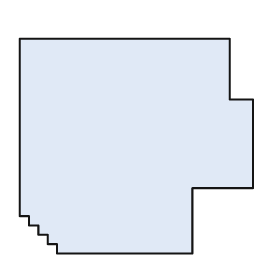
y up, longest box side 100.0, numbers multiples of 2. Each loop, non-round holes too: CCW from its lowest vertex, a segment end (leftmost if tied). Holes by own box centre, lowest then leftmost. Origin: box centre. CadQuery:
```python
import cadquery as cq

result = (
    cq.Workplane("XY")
    .moveTo(-34.0, -46.0)
    .lineTo(24.0, -46.0)
    .lineTo(24.0, -18.0)
    .lineTo(50.0, -18.0)
    .lineTo(50.0, 20.0)
    .lineTo(40.0, 20.0)
    .lineTo(40.0, 46.0)
    .lineTo(-50.0, 46.0)
    .lineTo(-50.0, -30.0)
    .lineTo(-46.0, -30.0)
    .lineTo(-46.0, -34.0)
    .lineTo(-42.0, -34.0)
    .lineTo(-42.0, -38.0)
    .lineTo(-38.0, -38.0)
    .lineTo(-38.0, -42.0)
    .lineTo(-34.0, -42.0)
    .close()
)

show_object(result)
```